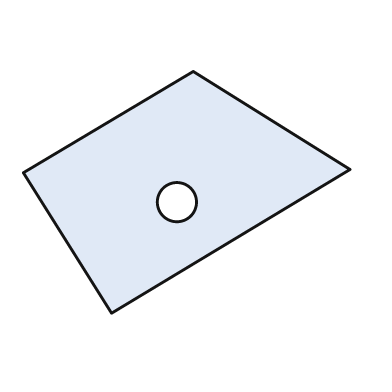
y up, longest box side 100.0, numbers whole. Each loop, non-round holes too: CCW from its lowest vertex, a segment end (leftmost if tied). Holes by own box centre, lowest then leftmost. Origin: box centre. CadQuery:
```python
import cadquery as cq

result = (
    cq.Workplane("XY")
    .moveTo(-23.0, -37.0)
    .lineTo(50.0, 7.0)
    .lineTo(2.0, 37.0)
    .lineTo(-50.0, 6.0)
    .close()
    .moveTo(-3.0, -3.0)
    .circle(6.0)
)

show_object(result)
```